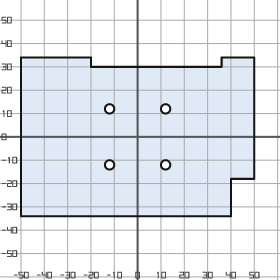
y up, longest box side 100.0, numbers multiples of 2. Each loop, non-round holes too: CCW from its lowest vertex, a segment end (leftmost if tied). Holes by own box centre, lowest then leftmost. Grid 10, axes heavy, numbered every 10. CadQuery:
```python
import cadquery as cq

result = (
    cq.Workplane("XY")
    .moveTo(-50.0, -34.0)
    .lineTo(40.0, -34.0)
    .lineTo(40.0, -18.0)
    .lineTo(50.0, -18.0)
    .lineTo(50.0, 34.0)
    .lineTo(36.0, 34.0)
    .lineTo(36.0, 30.0)
    .lineTo(-20.0, 30.0)
    .lineTo(-20.0, 34.0)
    .lineTo(-50.0, 34.0)
    .close()
    .moveTo(-12.0, -12.0)
    .circle(2.0)
    .moveTo(12.0, -12.0)
    .circle(2.0)
    .moveTo(-12.0, 12.0)
    .circle(2.0)
    .moveTo(12.0, 12.0)
    .circle(2.0)
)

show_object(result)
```